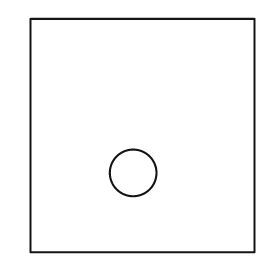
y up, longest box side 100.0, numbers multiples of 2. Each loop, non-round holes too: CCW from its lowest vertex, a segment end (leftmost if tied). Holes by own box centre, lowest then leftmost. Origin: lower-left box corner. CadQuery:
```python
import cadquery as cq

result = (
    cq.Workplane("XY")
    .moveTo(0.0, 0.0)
    .lineTo(96.0, 0.0)
    .lineTo(96.0, 100.0)
    .lineTo(0.0, 100.0)
    .close()
    .moveTo(44.0, 34.0)
    .circle(10.0)
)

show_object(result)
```